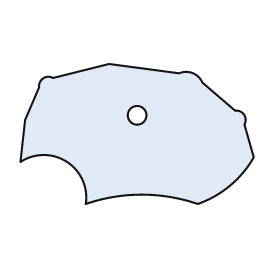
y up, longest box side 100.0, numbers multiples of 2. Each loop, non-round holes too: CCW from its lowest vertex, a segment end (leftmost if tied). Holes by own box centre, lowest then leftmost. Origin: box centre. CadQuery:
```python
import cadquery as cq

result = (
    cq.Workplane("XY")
    .moveTo(-22.0, -30.0)
    .threePointArc((2.0, -26.0), (26.0, -30.0))
    .threePointArc((40.0, -22.0), (50.0, -10.0))
    .lineTo(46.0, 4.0)
    .threePointArc((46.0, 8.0), (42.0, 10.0))
    .lineTo(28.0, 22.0)
    .threePointArc((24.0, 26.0), (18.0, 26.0))
    .lineTo(-12.0, 30.0)
    .lineTo(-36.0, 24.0)
    .threePointArc((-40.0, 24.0), (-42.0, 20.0))
    .lineTo(-48.0, 6.0)
    .lineTo(-50.0, -12.0)
    .threePointArc((-30.0, -12.0), (-22.0, -30.0))
    .close()
    .moveTo(0.0, 8.0)
    .circle(4.0)
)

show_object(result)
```